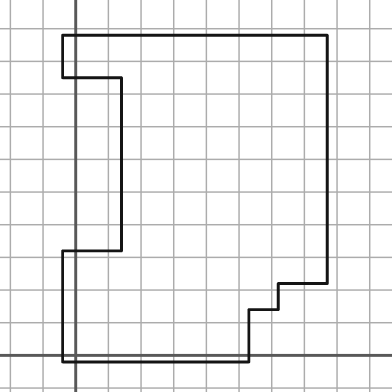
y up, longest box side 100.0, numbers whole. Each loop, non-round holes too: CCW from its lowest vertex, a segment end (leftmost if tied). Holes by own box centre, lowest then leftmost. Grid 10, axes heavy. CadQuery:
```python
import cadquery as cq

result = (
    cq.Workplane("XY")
    .moveTo(-4.0, -2.0)
    .lineTo(53.0, -2.0)
    .lineTo(53.0, 14.0)
    .lineTo(62.0, 14.0)
    .lineTo(62.0, 22.0)
    .lineTo(77.0, 22.0)
    .lineTo(77.0, 98.0)
    .lineTo(-4.0, 98.0)
    .lineTo(-4.0, 85.0)
    .lineTo(14.0, 85.0)
    .lineTo(14.0, 32.0)
    .lineTo(-4.0, 32.0)
    .close()
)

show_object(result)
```